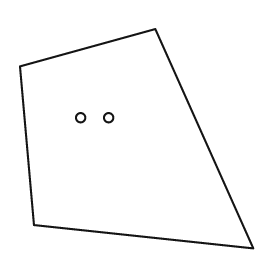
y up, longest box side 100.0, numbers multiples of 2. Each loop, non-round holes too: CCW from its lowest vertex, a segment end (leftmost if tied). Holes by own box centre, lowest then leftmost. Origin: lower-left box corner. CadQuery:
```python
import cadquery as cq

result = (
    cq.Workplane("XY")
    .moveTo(100.0, 0.0)
    .lineTo(58.0, 94.0)
    .lineTo(0.0, 78.0)
    .lineTo(6.0, 10.0)
    .close()
    .moveTo(26.0, 56.0)
    .circle(2.0)
    .moveTo(38.0, 56.0)
    .circle(2.0)
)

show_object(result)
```